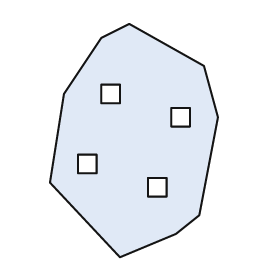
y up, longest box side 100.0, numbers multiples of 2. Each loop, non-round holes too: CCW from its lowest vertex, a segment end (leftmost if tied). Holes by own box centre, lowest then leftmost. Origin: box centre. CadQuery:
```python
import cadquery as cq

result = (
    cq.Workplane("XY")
    .moveTo(-6.0, -50.0)
    .lineTo(18.0, -40.0)
    .lineTo(28.0, -32.0)
    .lineTo(36.0, 10.0)
    .lineTo(30.0, 32.0)
    .lineTo(-2.0, 50.0)
    .lineTo(-14.0, 44.0)
    .lineTo(-30.0, 20.0)
    .lineTo(-36.0, -18.0)
    .close()
    .moveTo(6.0, -24.0)
    .lineTo(14.0, -24.0)
    .lineTo(14.0, -16.0)
    .lineTo(6.0, -16.0)
    .close()
    .moveTo(-24.0, -14.0)
    .lineTo(-16.0, -14.0)
    .lineTo(-16.0, -6.0)
    .lineTo(-24.0, -6.0)
    .close()
    .moveTo(16.0, 6.0)
    .lineTo(24.0, 6.0)
    .lineTo(24.0, 14.0)
    .lineTo(16.0, 14.0)
    .close()
    .moveTo(-14.0, 16.0)
    .lineTo(-6.0, 16.0)
    .lineTo(-6.0, 24.0)
    .lineTo(-14.0, 24.0)
    .close()
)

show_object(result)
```